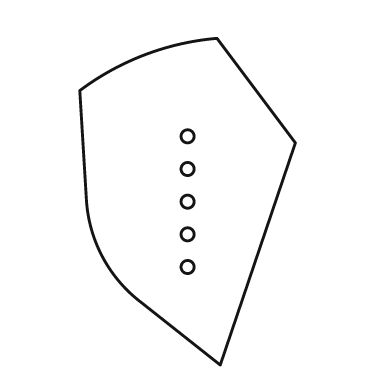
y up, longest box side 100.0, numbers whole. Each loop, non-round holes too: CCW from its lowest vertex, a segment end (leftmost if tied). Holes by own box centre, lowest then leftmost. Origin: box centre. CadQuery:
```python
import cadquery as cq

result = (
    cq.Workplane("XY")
    .moveTo(10.0, -50.0)
    .lineTo(33.0, 18.0)
    .lineTo(9.0, 50.0)
    .threePointArc((-13.0, 45.0), (-33.0, 34.0))
    .lineTo(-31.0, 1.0)
    .threePointArc((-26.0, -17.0), (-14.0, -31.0))
    .close()
    .moveTo(0.0, -20.0)
    .circle(2.0)
    .moveTo(0.0, -10.0)
    .circle(2.0)
    .moveTo(0.0, 0.0)
    .circle(2.0)
    .moveTo(0.0, 10.0)
    .circle(2.0)
    .moveTo(0.0, 20.0)
    .circle(2.0)
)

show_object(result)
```